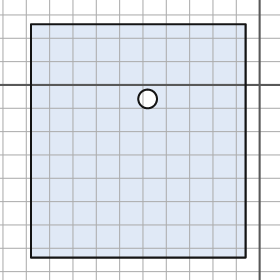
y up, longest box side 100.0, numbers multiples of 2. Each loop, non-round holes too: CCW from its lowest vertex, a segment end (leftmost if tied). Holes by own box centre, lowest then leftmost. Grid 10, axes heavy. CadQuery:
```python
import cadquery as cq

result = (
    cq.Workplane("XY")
    .moveTo(-98.0, -74.0)
    .lineTo(-6.0, -74.0)
    .lineTo(-6.0, 26.0)
    .lineTo(-98.0, 26.0)
    .close()
    .moveTo(-48.0, -6.0)
    .circle(4.0)
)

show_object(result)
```